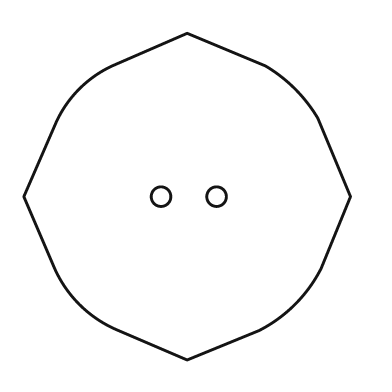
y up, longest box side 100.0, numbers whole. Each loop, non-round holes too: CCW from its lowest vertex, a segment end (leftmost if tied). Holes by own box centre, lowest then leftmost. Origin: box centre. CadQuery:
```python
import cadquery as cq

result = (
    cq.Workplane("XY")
    .moveTo(0.0, -50.0)
    .lineTo(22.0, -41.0)
    .threePointArc((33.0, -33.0), (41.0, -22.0))
    .lineTo(50.0, 0.0)
    .lineTo(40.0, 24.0)
    .threePointArc((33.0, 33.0), (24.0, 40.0))
    .lineTo(0.0, 50.0)
    .lineTo(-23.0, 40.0)
    .threePointArc((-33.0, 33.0), (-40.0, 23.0))
    .lineTo(-50.0, 0.0)
    .lineTo(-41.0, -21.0)
    .threePointArc((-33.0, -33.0), (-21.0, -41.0))
    .close()
    .moveTo(-8.0, 0.0)
    .circle(3.0)
    .moveTo(9.0, 0.0)
    .circle(3.0)
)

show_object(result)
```